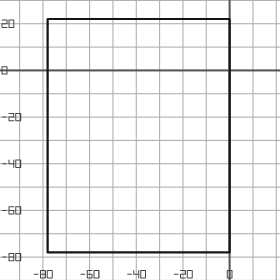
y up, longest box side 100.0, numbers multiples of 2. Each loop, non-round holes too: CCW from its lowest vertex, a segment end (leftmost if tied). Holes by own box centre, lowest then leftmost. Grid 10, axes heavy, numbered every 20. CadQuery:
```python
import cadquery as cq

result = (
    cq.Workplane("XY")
    .moveTo(-78.0, -78.0)
    .lineTo(0.0, -78.0)
    .lineTo(0.0, 22.0)
    .lineTo(-78.0, 22.0)
    .close()
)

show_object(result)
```